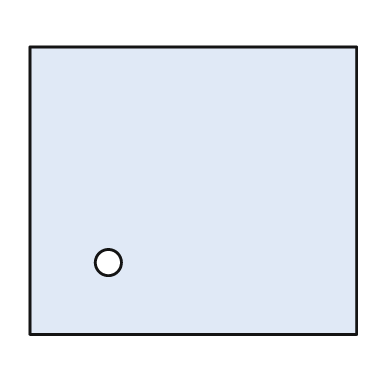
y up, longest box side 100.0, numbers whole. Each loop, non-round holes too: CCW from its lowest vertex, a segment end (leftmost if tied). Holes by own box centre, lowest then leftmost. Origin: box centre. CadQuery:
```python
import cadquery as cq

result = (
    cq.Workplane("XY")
    .moveTo(-50.0, -44.0)
    .lineTo(50.0, -44.0)
    .lineTo(50.0, 44.0)
    .lineTo(-50.0, 44.0)
    .close()
    .moveTo(-26.0, -22.0)
    .circle(4.0)
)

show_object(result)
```